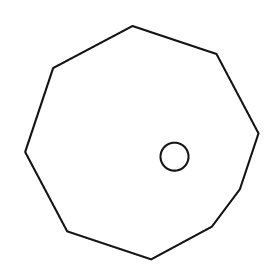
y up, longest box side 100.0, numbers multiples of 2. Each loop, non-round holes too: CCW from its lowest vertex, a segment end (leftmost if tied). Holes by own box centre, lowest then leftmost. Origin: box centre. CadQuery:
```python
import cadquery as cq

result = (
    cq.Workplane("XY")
    .moveTo(4.0, -50.0)
    .lineTo(30.0, -36.0)
    .lineTo(42.0, -20.0)
    .lineTo(50.0, 4.0)
    .lineTo(32.0, 38.0)
    .lineTo(-4.0, 50.0)
    .lineTo(-38.0, 32.0)
    .lineTo(-50.0, -4.0)
    .lineTo(-32.0, -38.0)
    .close()
    .moveTo(14.0, -6.0)
    .circle(6.0)
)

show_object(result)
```